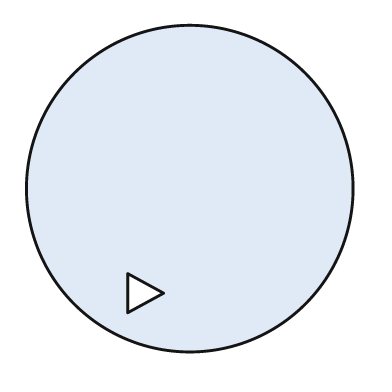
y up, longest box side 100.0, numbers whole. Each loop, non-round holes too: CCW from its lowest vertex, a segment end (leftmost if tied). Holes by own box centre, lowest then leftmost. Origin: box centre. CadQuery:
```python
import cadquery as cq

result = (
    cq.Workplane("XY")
    .moveTo(0.0, 0.0)
    .circle(50.0)
    .moveTo(-19.0, -38.0)
    .lineTo(-8.0, -32.0)
    .lineTo(-19.0, -26.0)
    .close()
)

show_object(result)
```